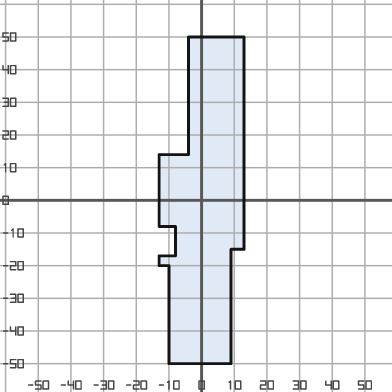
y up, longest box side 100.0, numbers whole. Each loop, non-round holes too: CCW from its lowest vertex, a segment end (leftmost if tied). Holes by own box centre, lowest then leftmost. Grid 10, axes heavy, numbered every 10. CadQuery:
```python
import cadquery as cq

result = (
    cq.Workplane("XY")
    .moveTo(-10.0, -50.0)
    .lineTo(9.0, -50.0)
    .lineTo(9.0, -15.0)
    .lineTo(13.0, -15.0)
    .lineTo(13.0, 50.0)
    .lineTo(-4.0, 50.0)
    .lineTo(-4.0, 14.0)
    .lineTo(-13.0, 14.0)
    .lineTo(-13.0, -8.0)
    .lineTo(-8.0, -8.0)
    .lineTo(-8.0, -17.0)
    .lineTo(-13.0, -17.0)
    .lineTo(-13.0, -20.0)
    .lineTo(-10.0, -20.0)
    .close()
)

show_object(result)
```